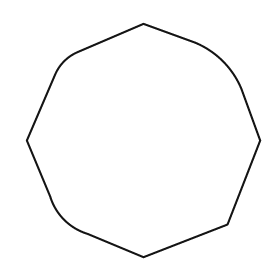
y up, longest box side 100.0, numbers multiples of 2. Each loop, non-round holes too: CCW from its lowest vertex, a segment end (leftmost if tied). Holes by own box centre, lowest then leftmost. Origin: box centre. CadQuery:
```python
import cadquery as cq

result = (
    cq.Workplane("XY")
    .moveTo(0.0, -50.0)
    .lineTo(36.0, -36.0)
    .lineTo(50.0, 0.0)
    .lineTo(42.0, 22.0)
    .threePointArc((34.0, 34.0), (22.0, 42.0))
    .lineTo(0.0, 50.0)
    .lineTo(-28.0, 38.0)
    .threePointArc((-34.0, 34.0), (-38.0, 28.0))
    .lineTo(-50.0, 0.0)
    .lineTo(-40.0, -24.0)
    .threePointArc((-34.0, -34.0), (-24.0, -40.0))
    .close()
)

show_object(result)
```